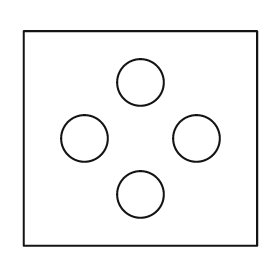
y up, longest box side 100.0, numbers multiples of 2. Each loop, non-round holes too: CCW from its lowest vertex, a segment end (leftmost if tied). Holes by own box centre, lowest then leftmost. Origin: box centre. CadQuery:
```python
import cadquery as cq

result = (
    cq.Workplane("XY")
    .moveTo(-50.0, -46.0)
    .lineTo(50.0, -46.0)
    .lineTo(50.0, 46.0)
    .lineTo(-50.0, 46.0)
    .close()
    .moveTo(0.0, -24.0)
    .circle(10.0)
    .moveTo(-24.0, 0.0)
    .circle(10.0)
    .moveTo(24.0, 0.0)
    .circle(10.0)
    .moveTo(0.0, 24.0)
    .circle(10.0)
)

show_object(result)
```